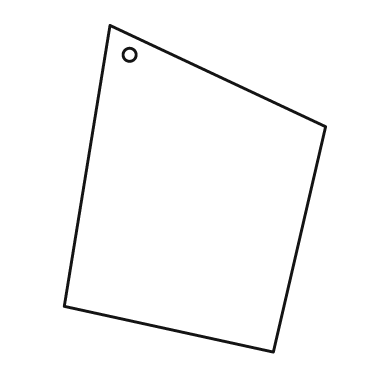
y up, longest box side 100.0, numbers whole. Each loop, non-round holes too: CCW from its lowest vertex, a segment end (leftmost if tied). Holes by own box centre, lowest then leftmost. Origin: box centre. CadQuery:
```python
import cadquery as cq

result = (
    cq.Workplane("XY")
    .moveTo(24.0, -50.0)
    .lineTo(40.0, 19.0)
    .lineTo(-26.0, 50.0)
    .lineTo(-40.0, -36.0)
    .close()
    .moveTo(-20.0, 41.0)
    .circle(2.0)
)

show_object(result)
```